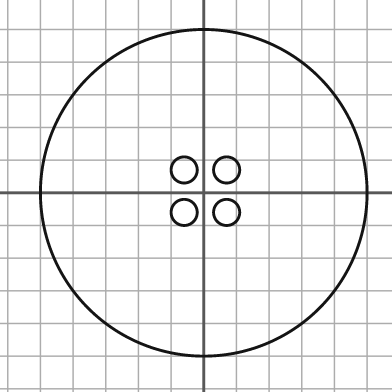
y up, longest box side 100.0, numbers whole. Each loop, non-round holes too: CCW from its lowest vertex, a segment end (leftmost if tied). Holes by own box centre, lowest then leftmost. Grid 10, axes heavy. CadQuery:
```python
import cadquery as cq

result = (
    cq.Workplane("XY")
    .moveTo(0.0, 0.0)
    .circle(50.0)
    .moveTo(-6.0, -6.0)
    .circle(4.0)
    .moveTo(7.0, -6.0)
    .circle(4.0)
    .moveTo(-6.0, 7.0)
    .circle(4.0)
    .moveTo(7.0, 7.0)
    .circle(4.0)
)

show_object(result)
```